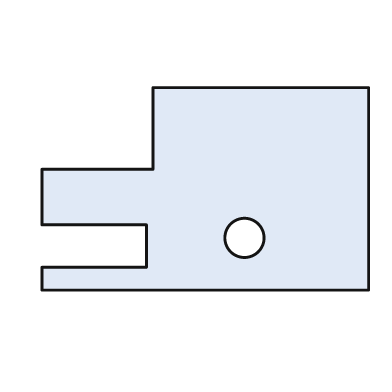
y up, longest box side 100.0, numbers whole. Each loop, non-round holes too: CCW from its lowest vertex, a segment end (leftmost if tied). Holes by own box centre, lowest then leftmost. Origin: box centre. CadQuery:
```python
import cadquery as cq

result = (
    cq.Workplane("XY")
    .moveTo(-50.0, -31.0)
    .lineTo(50.0, -31.0)
    .lineTo(50.0, 31.0)
    .lineTo(-16.0, 31.0)
    .lineTo(-16.0, 6.0)
    .lineTo(-50.0, 6.0)
    .lineTo(-50.0, -11.0)
    .lineTo(-18.0, -11.0)
    .lineTo(-18.0, -24.0)
    .lineTo(-50.0, -24.0)
    .close()
    .moveTo(12.0, -15.0)
    .circle(6.0)
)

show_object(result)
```